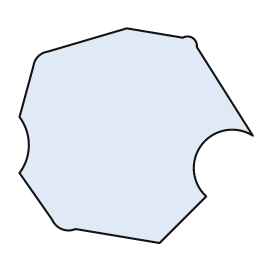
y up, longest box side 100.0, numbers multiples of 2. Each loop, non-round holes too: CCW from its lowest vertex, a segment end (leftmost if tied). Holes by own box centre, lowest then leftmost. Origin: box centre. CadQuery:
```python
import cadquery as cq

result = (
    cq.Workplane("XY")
    .moveTo(10.0, -46.0)
    .lineTo(30.0, -26.0)
    .threePointArc((28.0, -4.0), (50.0, 0.0))
    .lineTo(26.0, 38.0)
    .threePointArc((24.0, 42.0), (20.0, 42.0))
    .lineTo(-4.0, 46.0)
    .lineTo(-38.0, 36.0)
    .threePointArc((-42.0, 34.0), (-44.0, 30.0))
    .lineTo(-50.0, 8.0)
    .threePointArc((-46.0, -4.0), (-50.0, -16.0))
    .lineTo(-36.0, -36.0)
    .threePointArc((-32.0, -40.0), (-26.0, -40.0))
    .close()
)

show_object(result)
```